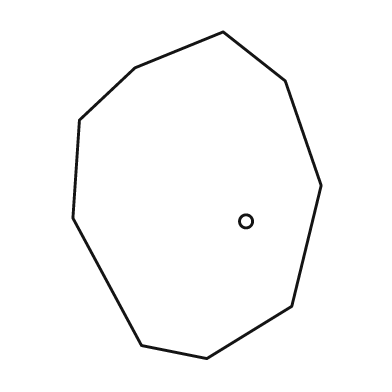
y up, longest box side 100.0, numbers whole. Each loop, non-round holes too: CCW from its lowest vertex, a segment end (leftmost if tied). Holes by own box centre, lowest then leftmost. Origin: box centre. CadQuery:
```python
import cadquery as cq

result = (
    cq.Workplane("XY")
    .moveTo(3.0, -50.0)
    .lineTo(29.0, -34.0)
    .lineTo(38.0, 3.0)
    .lineTo(27.0, 35.0)
    .lineTo(8.0, 50.0)
    .lineTo(-19.0, 39.0)
    .lineTo(-36.0, 23.0)
    .lineTo(-38.0, -7.0)
    .lineTo(-17.0, -46.0)
    .close()
    .moveTo(15.0, -8.0)
    .circle(2.0)
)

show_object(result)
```